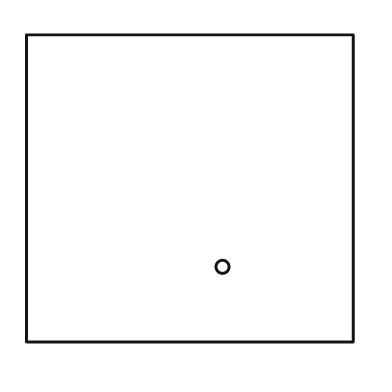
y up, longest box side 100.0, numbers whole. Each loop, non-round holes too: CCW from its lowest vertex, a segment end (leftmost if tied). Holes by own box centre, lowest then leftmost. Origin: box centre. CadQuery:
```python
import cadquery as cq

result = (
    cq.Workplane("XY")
    .moveTo(-50.0, -47.0)
    .lineTo(50.0, -47.0)
    .lineTo(50.0, 47.0)
    .lineTo(-50.0, 47.0)
    .close()
    .moveTo(10.0, -24.0)
    .circle(2.0)
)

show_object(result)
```